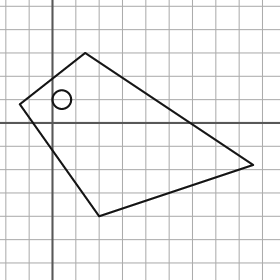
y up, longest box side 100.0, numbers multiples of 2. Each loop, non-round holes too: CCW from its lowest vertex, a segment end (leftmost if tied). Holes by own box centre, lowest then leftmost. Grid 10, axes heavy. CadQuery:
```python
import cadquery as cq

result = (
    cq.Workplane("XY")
    .moveTo(20.0, -40.0)
    .lineTo(86.0, -18.0)
    .lineTo(14.0, 30.0)
    .lineTo(-14.0, 8.0)
    .close()
    .moveTo(4.0, 10.0)
    .circle(4.0)
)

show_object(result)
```